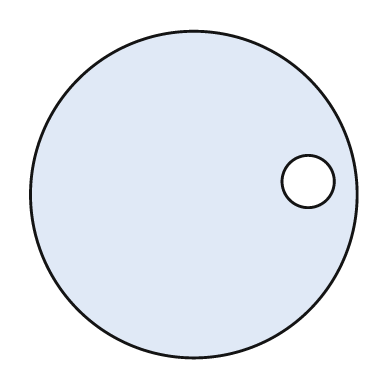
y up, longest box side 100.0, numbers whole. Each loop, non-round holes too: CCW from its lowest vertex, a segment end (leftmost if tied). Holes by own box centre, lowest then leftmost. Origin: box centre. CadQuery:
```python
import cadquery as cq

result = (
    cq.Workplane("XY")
    .moveTo(0.0, 0.0)
    .circle(50.0)
    .moveTo(35.0, 4.0)
    .circle(8.0)
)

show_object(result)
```